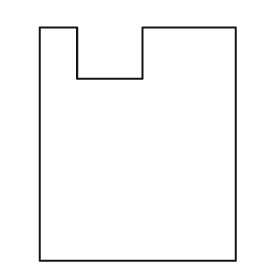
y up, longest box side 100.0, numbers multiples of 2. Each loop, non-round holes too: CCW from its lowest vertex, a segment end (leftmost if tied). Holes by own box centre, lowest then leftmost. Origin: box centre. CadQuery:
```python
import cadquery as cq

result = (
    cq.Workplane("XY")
    .moveTo(-42.0, -50.0)
    .lineTo(42.0, -50.0)
    .lineTo(42.0, 50.0)
    .lineTo(2.0, 50.0)
    .lineTo(2.0, 28.0)
    .lineTo(-26.0, 28.0)
    .lineTo(-26.0, 50.0)
    .lineTo(-42.0, 50.0)
    .close()
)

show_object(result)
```